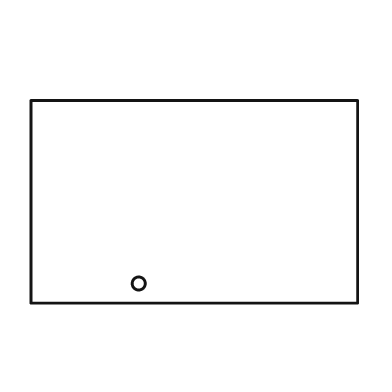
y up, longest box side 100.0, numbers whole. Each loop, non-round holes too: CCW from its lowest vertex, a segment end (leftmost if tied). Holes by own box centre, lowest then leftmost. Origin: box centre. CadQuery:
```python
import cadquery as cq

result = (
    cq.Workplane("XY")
    .moveTo(-50.0, -31.0)
    .lineTo(50.0, -31.0)
    .lineTo(50.0, 31.0)
    .lineTo(-50.0, 31.0)
    .close()
    .moveTo(-17.0, -25.0)
    .circle(2.0)
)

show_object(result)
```